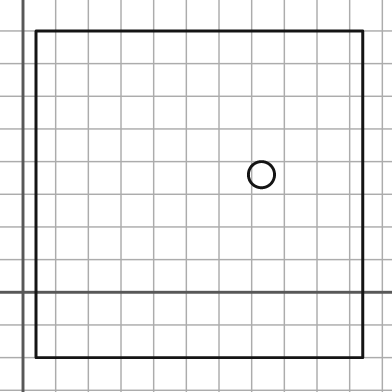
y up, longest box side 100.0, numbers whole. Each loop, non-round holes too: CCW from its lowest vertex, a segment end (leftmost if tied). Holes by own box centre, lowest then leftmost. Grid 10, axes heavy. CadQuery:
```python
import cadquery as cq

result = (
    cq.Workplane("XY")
    .moveTo(4.0, -20.0)
    .lineTo(104.0, -20.0)
    .lineTo(104.0, 80.0)
    .lineTo(4.0, 80.0)
    .close()
    .moveTo(73.0, 36.0)
    .circle(4.0)
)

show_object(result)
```